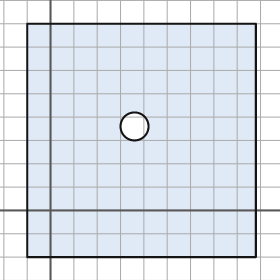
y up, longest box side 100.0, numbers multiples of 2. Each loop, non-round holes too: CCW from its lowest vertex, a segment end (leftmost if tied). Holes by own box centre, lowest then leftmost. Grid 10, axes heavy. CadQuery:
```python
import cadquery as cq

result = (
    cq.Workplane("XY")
    .moveTo(-10.0, -20.0)
    .lineTo(88.0, -20.0)
    .lineTo(88.0, 80.0)
    .lineTo(-10.0, 80.0)
    .close()
    .moveTo(36.0, 36.0)
    .circle(6.0)
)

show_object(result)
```